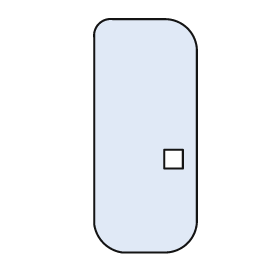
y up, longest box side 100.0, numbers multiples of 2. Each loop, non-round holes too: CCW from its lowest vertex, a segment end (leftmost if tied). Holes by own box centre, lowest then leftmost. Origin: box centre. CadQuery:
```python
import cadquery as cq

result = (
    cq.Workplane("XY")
    .moveTo(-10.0, -50.0)
    .lineTo(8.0, -50.0)
    .threePointArc((18.0, -46.0), (22.0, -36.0))
    .lineTo(22.0, 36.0)
    .threePointArc((18.0, 46.0), (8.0, 50.0))
    .lineTo(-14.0, 50.0)
    .threePointArc((-20.0, 48.0), (-22.0, 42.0))
    .lineTo(-22.0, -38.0)
    .threePointArc((-18.0, -46.0), (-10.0, -50.0))
    .close()
    .moveTo(8.0, -14.0)
    .lineTo(16.0, -14.0)
    .lineTo(16.0, -6.0)
    .lineTo(8.0, -6.0)
    .close()
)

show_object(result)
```